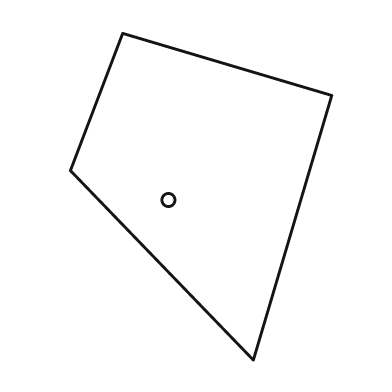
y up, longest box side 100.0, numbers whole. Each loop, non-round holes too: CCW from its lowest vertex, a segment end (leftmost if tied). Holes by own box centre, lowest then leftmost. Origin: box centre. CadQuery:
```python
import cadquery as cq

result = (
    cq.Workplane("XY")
    .moveTo(16.0, -50.0)
    .lineTo(40.0, 31.0)
    .lineTo(-24.0, 50.0)
    .lineTo(-40.0, 8.0)
    .close()
    .moveTo(-10.0, -1.0)
    .circle(2.0)
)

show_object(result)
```